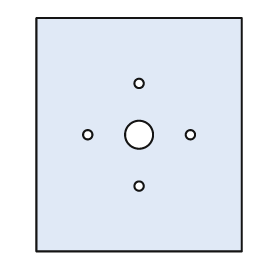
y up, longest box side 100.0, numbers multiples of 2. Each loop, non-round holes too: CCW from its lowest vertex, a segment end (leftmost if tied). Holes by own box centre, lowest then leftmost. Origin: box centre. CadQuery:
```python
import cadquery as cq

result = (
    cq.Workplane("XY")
    .moveTo(-44.0, -50.0)
    .lineTo(44.0, -50.0)
    .lineTo(44.0, 50.0)
    .lineTo(-44.0, 50.0)
    .close()
    .moveTo(0.0, -22.0)
    .circle(2.0)
    .moveTo(-22.0, 0.0)
    .circle(2.0)
    .moveTo(0.0, 0.0)
    .circle(6.0)
    .moveTo(22.0, 0.0)
    .circle(2.0)
    .moveTo(0.0, 22.0)
    .circle(2.0)
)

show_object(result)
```